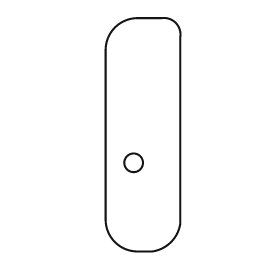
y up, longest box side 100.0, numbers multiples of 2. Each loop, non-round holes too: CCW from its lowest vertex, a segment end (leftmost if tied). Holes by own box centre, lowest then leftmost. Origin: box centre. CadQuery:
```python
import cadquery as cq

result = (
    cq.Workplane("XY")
    .moveTo(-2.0, -50.0)
    .lineTo(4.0, -50.0)
    .threePointArc((12.0, -46.0), (16.0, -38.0))
    .lineTo(16.0, 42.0)
    .threePointArc((14.0, 48.0), (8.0, 50.0))
    .lineTo(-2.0, 50.0)
    .threePointArc((-12.0, 46.0), (-16.0, 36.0))
    .lineTo(-16.0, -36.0)
    .threePointArc((-12.0, -46.0), (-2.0, -50.0))
    .close()
    .moveTo(-4.0, -12.0)
    .circle(4.0)
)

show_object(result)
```